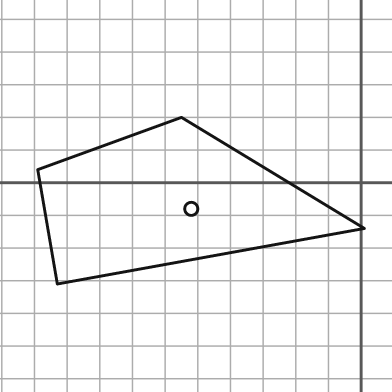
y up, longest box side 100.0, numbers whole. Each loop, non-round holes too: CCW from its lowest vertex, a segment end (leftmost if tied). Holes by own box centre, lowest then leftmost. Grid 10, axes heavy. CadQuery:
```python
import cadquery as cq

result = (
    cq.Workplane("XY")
    .moveTo(-93.0, -31.0)
    .lineTo(1.0, -14.0)
    .lineTo(-55.0, 20.0)
    .lineTo(-99.0, 4.0)
    .close()
    .moveTo(-52.0, -8.0)
    .circle(2.0)
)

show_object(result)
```